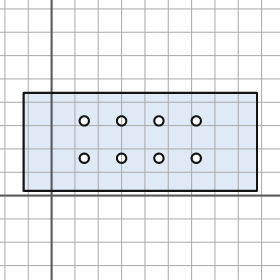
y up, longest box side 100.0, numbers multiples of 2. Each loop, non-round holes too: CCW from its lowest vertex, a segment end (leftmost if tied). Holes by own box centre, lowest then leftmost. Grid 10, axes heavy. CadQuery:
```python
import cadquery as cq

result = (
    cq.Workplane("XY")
    .moveTo(-12.0, 2.0)
    .lineTo(88.0, 2.0)
    .lineTo(88.0, 44.0)
    .lineTo(-12.0, 44.0)
    .close()
    .moveTo(14.0, 16.0)
    .circle(2.0)
    .moveTo(30.0, 16.0)
    .circle(2.0)
    .moveTo(46.0, 16.0)
    .circle(2.0)
    .moveTo(62.0, 16.0)
    .circle(2.0)
    .moveTo(14.0, 32.0)
    .circle(2.0)
    .moveTo(30.0, 32.0)
    .circle(2.0)
    .moveTo(46.0, 32.0)
    .circle(2.0)
    .moveTo(62.0, 32.0)
    .circle(2.0)
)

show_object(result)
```